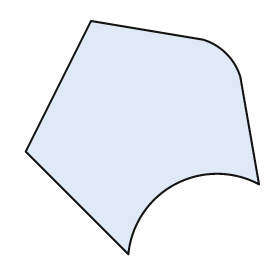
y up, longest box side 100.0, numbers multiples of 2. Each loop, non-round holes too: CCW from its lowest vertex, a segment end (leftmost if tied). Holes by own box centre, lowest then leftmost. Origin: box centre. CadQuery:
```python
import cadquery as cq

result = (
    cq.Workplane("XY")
    .moveTo(-6.0, -50.0)
    .threePointArc((14.0, -20.0), (50.0, -20.0))
    .lineTo(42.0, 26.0)
    .threePointArc((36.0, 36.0), (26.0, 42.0))
    .lineTo(-22.0, 50.0)
    .lineTo(-50.0, -6.0)
    .close()
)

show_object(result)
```